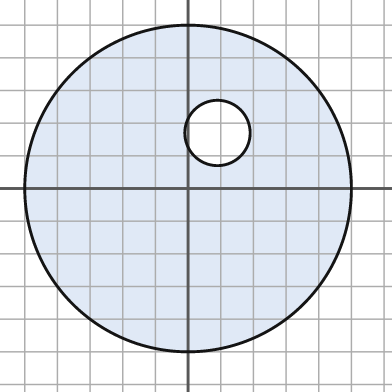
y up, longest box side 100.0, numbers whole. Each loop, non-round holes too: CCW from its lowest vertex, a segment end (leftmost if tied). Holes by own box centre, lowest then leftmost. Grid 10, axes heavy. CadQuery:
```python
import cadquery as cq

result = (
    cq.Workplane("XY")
    .moveTo(0.0, 0.0)
    .circle(50.0)
    .moveTo(9.0, 17.0)
    .circle(10.0)
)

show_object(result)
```